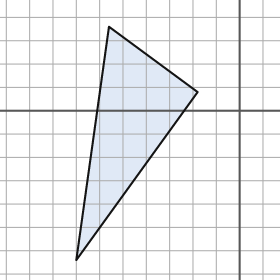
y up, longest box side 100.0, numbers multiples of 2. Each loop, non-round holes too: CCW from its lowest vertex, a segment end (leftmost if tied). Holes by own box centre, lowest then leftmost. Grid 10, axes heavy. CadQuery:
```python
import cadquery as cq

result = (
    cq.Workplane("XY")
    .moveTo(-70.0, -64.0)
    .lineTo(-18.0, 8.0)
    .lineTo(-56.0, 36.0)
    .close()
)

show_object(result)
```